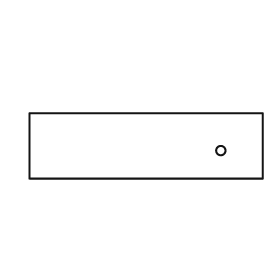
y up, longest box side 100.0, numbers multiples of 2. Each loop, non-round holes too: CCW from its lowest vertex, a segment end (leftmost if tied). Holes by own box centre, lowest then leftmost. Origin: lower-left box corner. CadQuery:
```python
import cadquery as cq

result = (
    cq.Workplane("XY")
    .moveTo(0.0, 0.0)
    .lineTo(100.0, 0.0)
    .lineTo(100.0, 28.0)
    .lineTo(0.0, 28.0)
    .close()
    .moveTo(82.0, 12.0)
    .circle(2.0)
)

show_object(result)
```